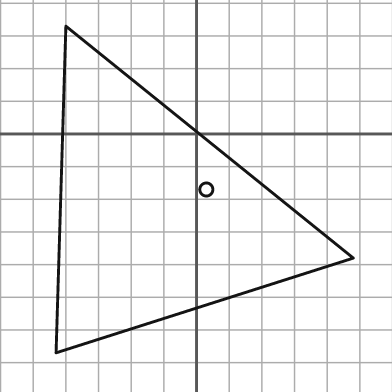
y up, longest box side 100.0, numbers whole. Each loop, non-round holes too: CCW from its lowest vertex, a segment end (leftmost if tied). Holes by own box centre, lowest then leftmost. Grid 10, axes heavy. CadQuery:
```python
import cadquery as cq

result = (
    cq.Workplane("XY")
    .moveTo(-43.0, -67.0)
    .lineTo(48.0, -38.0)
    .lineTo(-40.0, 33.0)
    .close()
    .moveTo(3.0, -17.0)
    .circle(2.0)
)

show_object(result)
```